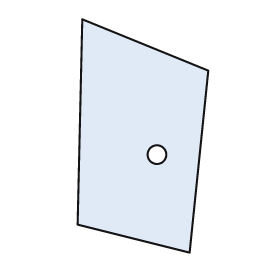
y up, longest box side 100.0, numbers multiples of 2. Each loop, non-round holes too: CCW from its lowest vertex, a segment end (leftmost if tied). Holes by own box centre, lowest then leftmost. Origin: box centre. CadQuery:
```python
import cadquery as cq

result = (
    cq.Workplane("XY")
    .moveTo(20.0, -50.0)
    .lineTo(28.0, 28.0)
    .lineTo(-26.0, 50.0)
    .lineTo(-28.0, -38.0)
    .close()
    .moveTo(6.0, -8.0)
    .circle(4.0)
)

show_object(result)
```